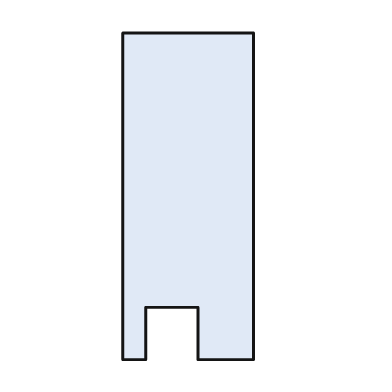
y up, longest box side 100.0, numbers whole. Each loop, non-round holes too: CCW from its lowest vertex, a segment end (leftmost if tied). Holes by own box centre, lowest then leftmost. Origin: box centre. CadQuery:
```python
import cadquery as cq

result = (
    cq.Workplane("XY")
    .moveTo(-20.0, -50.0)
    .lineTo(-13.0, -50.0)
    .lineTo(-13.0, -34.0)
    .lineTo(3.0, -34.0)
    .lineTo(3.0, -50.0)
    .lineTo(20.0, -50.0)
    .lineTo(20.0, 50.0)
    .lineTo(-20.0, 50.0)
    .close()
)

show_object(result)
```